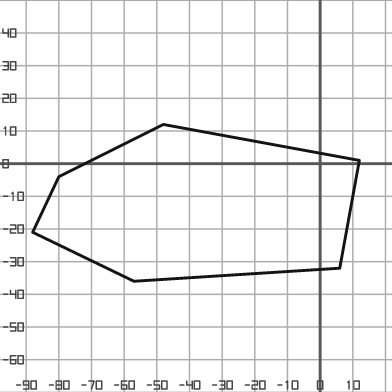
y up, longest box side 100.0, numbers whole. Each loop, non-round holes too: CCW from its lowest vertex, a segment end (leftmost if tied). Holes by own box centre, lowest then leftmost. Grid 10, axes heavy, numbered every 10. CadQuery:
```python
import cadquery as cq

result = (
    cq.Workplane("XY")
    .moveTo(-57.0, -36.0)
    .lineTo(6.0, -32.0)
    .lineTo(12.0, 1.0)
    .lineTo(-48.0, 12.0)
    .lineTo(-80.0, -4.0)
    .lineTo(-88.0, -21.0)
    .close()
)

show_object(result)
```